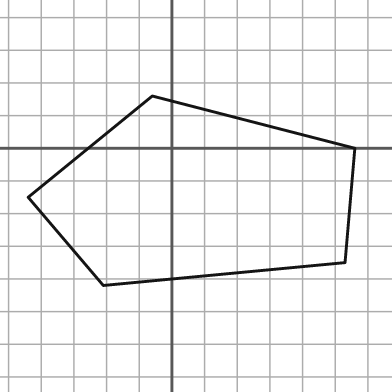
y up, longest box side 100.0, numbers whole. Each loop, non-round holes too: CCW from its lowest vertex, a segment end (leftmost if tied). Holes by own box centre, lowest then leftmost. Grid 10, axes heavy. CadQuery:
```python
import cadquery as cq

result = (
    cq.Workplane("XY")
    .moveTo(-21.0, -42.0)
    .lineTo(53.0, -35.0)
    .lineTo(56.0, 0.0)
    .lineTo(-6.0, 16.0)
    .lineTo(-44.0, -15.0)
    .close()
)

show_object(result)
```